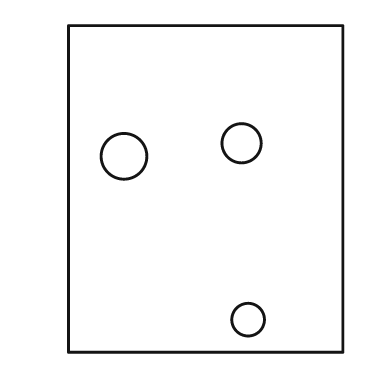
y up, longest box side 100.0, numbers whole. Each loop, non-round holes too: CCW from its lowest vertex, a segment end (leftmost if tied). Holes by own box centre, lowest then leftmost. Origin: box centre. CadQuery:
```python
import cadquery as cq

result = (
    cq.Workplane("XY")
    .moveTo(-42.0, -50.0)
    .lineTo(42.0, -50.0)
    .lineTo(42.0, 50.0)
    .lineTo(-42.0, 50.0)
    .close()
    .moveTo(13.0, -40.0)
    .circle(5.0)
    .moveTo(-25.0, 10.0)
    .circle(7.0)
    .moveTo(11.0, 14.0)
    .circle(6.0)
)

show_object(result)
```